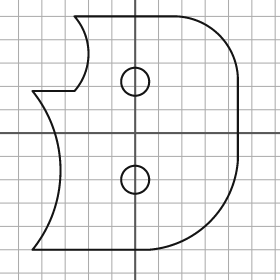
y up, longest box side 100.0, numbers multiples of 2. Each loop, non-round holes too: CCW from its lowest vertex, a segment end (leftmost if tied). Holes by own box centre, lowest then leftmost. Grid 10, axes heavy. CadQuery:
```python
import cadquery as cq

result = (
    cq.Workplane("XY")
    .moveTo(-44.0, -50.0)
    .lineTo(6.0, -50.0)
    .threePointArc((32.0, -38.0), (44.0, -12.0))
    .lineTo(44.0, 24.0)
    .threePointArc((36.0, 42.0), (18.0, 50.0))
    .lineTo(-26.0, 50.0)
    .threePointArc((-20.0, 34.0), (-26.0, 18.0))
    .lineTo(-44.0, 18.0)
    .threePointArc((-32.0, -16.0), (-44.0, -50.0))
    .close()
    .moveTo(0.0, -20.0)
    .circle(6.0)
    .moveTo(0.0, 22.0)
    .circle(6.0)
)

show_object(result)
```